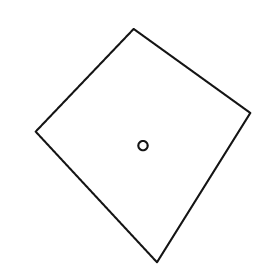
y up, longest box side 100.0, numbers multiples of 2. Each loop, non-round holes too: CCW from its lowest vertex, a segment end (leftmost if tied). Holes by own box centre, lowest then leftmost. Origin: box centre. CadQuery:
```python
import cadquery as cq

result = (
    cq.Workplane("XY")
    .moveTo(6.0, -50.0)
    .lineTo(46.0, 14.0)
    .lineTo(-4.0, 50.0)
    .lineTo(-46.0, 6.0)
    .close()
    .moveTo(0.0, 0.0)
    .circle(2.0)
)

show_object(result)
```